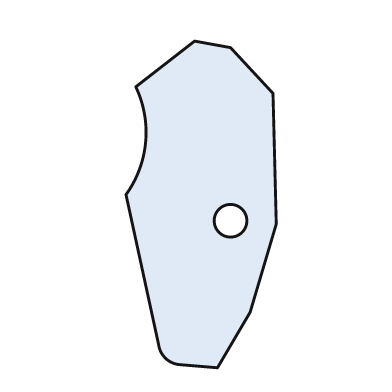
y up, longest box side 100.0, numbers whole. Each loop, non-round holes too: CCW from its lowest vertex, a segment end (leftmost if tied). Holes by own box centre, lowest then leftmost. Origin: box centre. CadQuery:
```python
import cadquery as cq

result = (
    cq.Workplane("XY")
    .moveTo(5.0, -50.0)
    .lineTo(15.0, -33.0)
    .lineTo(23.0, -6.0)
    .lineTo(22.0, 34.0)
    .lineTo(9.0, 48.0)
    .lineTo(-2.0, 50.0)
    .lineTo(-20.0, 36.0)
    .threePointArc((-17.0, 19.0), (-23.0, 3.0))
    .lineTo(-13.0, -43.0)
    .threePointArc((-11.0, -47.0), (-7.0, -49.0))
    .close()
    .moveTo(9.0, -5.0)
    .circle(5.0)
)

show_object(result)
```